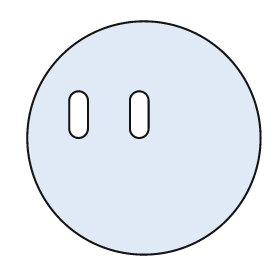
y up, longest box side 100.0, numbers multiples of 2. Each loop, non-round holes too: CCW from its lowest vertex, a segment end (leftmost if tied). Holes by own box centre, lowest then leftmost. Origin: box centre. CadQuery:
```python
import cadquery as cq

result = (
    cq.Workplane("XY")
    .moveTo(0.0, 0.0)
    .circle(50.0)
    .moveTo(-32.0, 4.0)
    .threePointArc((-28.0, 0.0), (-24.0, 4.0))
    .lineTo(-24.0, 16.0)
    .threePointArc((-28.0, 20.0), (-32.0, 16.0))
    .close()
    .moveTo(-6.0, 4.0)
    .threePointArc((-2.0, 0.0), (2.0, 4.0))
    .lineTo(2.0, 16.0)
    .threePointArc((-2.0, 20.0), (-6.0, 16.0))
    .close()
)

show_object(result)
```